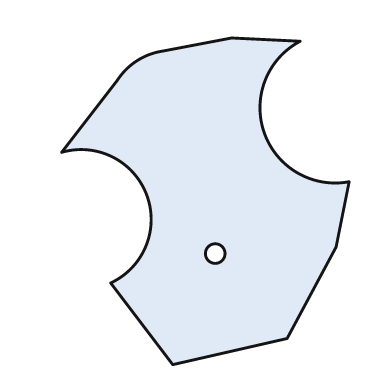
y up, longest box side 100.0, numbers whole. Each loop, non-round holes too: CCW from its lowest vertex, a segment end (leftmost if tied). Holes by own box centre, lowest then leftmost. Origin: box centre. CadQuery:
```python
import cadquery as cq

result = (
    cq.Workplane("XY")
    .moveTo(-10.0, -50.0)
    .lineTo(25.0, -42.0)
    .lineTo(40.0, -14.0)
    .lineTo(44.0, 6.0)
    .threePointArc((18.0, 21.0), (29.0, 49.0))
    .lineTo(8.0, 50.0)
    .lineTo(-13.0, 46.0)
    .threePointArc((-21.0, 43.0), (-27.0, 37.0))
    .lineTo(-44.0, 15.0)
    .threePointArc((-18.0, 2.0), (-29.0, -25.0))
    .close()
    .moveTo(3.0, -16.0)
    .circle(3.0)
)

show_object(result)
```